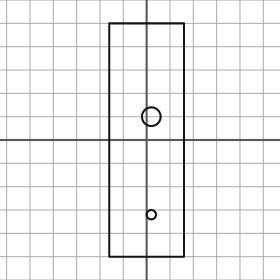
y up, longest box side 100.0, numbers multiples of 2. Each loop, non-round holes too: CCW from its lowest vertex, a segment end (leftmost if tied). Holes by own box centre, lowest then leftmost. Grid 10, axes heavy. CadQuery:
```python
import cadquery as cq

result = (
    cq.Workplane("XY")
    .moveTo(-16.0, -50.0)
    .lineTo(16.0, -50.0)
    .lineTo(16.0, 50.0)
    .lineTo(-16.0, 50.0)
    .close()
    .moveTo(2.0, -32.0)
    .circle(2.0)
    .moveTo(2.0, 10.0)
    .circle(4.0)
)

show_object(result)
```